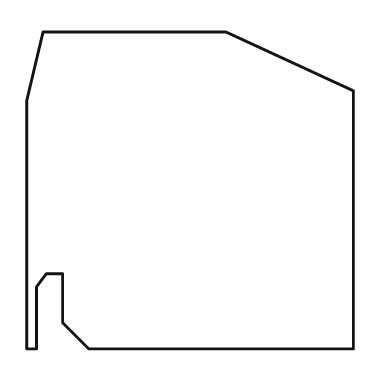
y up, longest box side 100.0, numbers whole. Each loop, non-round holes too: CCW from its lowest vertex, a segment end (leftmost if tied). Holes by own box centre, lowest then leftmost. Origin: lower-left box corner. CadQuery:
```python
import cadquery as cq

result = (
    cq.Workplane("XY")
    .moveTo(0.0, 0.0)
    .lineTo(3.0, 0.0)
    .lineTo(3.0, 19.0)
    .lineTo(6.0, 23.0)
    .lineTo(11.0, 23.0)
    .lineTo(11.0, 8.0)
    .lineTo(19.0, 0.0)
    .lineTo(100.0, 0.0)
    .lineTo(100.0, 79.0)
    .lineTo(61.0, 97.0)
    .lineTo(5.0, 97.0)
    .lineTo(0.0, 76.0)
    .close()
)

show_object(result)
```